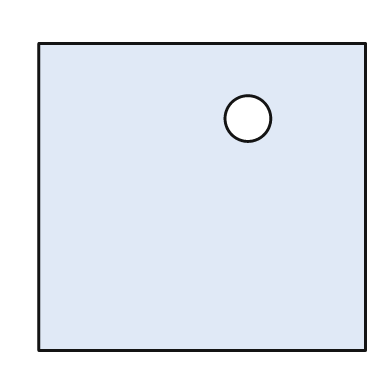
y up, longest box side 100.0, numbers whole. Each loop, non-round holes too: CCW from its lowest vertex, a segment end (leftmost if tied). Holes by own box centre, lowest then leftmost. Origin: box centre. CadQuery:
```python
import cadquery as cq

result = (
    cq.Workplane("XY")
    .moveTo(-50.0, -47.0)
    .lineTo(50.0, -47.0)
    .lineTo(50.0, 47.0)
    .lineTo(-50.0, 47.0)
    .close()
    .moveTo(14.0, 24.0)
    .circle(7.0)
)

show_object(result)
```